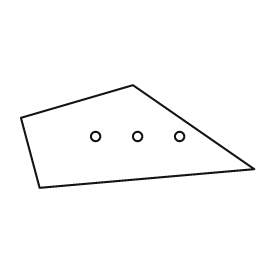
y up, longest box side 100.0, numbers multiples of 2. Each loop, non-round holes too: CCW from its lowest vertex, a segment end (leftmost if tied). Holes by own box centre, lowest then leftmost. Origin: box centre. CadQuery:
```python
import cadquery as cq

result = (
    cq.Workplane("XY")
    .moveTo(-42.0, -22.0)
    .lineTo(50.0, -14.0)
    .lineTo(-2.0, 22.0)
    .lineTo(-50.0, 8.0)
    .close()
    .moveTo(-18.0, 0.0)
    .circle(2.0)
    .moveTo(0.0, 0.0)
    .circle(2.0)
    .moveTo(18.0, 0.0)
    .circle(2.0)
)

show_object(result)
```